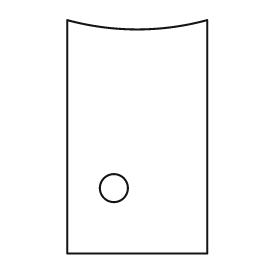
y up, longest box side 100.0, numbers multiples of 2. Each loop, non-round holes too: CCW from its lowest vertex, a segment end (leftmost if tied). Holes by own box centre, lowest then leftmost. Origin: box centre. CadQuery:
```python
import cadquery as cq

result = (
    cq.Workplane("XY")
    .moveTo(-30.0, -50.0)
    .lineTo(30.0, -50.0)
    .lineTo(30.0, 50.0)
    .threePointArc((0.0, 46.0), (-30.0, 50.0))
    .close()
    .moveTo(-10.0, -22.0)
    .circle(6.0)
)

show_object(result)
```